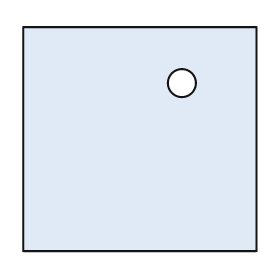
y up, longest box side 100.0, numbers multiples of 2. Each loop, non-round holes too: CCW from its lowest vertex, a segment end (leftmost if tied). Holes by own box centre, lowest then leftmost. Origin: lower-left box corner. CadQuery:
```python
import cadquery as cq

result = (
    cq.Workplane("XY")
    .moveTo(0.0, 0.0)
    .lineTo(100.0, 0.0)
    .lineTo(100.0, 96.0)
    .lineTo(0.0, 96.0)
    .close()
    .moveTo(68.0, 72.0)
    .circle(6.0)
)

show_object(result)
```